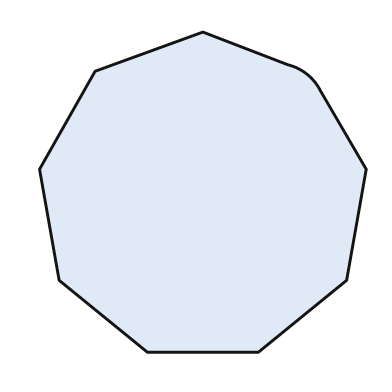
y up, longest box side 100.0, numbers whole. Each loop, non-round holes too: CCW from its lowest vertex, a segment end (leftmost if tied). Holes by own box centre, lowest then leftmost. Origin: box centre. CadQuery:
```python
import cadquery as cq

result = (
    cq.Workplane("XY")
    .moveTo(-17.0, -49.0)
    .lineTo(17.0, -49.0)
    .lineTo(44.0, -27.0)
    .lineTo(50.0, 7.0)
    .lineTo(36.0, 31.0)
    .threePointArc((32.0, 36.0), (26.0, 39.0))
    .lineTo(0.0, 49.0)
    .lineTo(-33.0, 37.0)
    .lineTo(-50.0, 7.0)
    .lineTo(-44.0, -27.0)
    .close()
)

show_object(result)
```